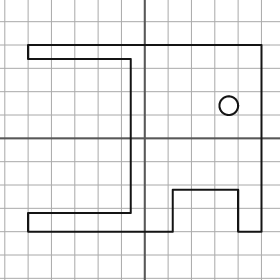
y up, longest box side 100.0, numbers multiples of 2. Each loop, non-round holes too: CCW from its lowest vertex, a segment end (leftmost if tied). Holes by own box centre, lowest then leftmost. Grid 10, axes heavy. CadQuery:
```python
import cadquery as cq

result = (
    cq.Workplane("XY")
    .moveTo(-50.0, -40.0)
    .lineTo(12.0, -40.0)
    .lineTo(12.0, -22.0)
    .lineTo(40.0, -22.0)
    .lineTo(40.0, -40.0)
    .lineTo(50.0, -40.0)
    .lineTo(50.0, 40.0)
    .lineTo(-50.0, 40.0)
    .lineTo(-50.0, 34.0)
    .lineTo(-6.0, 34.0)
    .lineTo(-6.0, -32.0)
    .lineTo(-50.0, -32.0)
    .close()
    .moveTo(36.0, 14.0)
    .circle(4.0)
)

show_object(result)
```